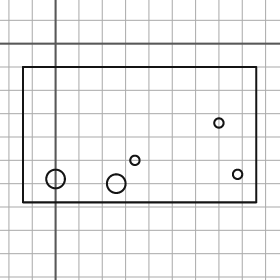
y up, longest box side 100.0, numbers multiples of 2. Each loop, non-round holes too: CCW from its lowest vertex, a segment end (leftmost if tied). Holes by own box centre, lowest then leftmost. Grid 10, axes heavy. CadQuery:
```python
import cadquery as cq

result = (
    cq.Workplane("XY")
    .moveTo(-14.0, -68.0)
    .lineTo(86.0, -68.0)
    .lineTo(86.0, -10.0)
    .lineTo(-14.0, -10.0)
    .close()
    .moveTo(26.0, -60.0)
    .circle(4.0)
    .moveTo(0.0, -58.0)
    .circle(4.0)
    .moveTo(78.0, -56.0)
    .circle(2.0)
    .moveTo(34.0, -50.0)
    .circle(2.0)
    .moveTo(70.0, -34.0)
    .circle(2.0)
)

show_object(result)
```